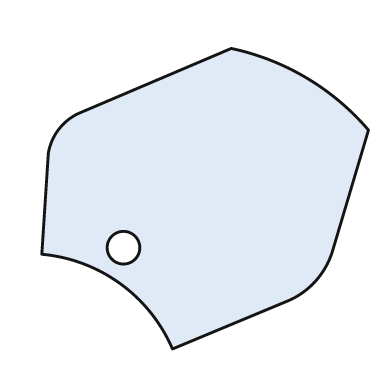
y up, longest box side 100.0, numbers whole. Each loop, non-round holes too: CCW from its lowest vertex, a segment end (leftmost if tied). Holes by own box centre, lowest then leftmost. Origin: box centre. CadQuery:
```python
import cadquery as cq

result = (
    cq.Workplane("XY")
    .moveTo(-10.0, -46.0)
    .lineTo(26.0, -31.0)
    .threePointArc((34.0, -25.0), (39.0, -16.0))
    .lineTo(50.0, 21.0)
    .threePointArc((31.0, 37.0), (8.0, 46.0))
    .lineTo(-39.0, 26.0)
    .threePointArc((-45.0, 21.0), (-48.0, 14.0))
    .lineTo(-50.0, -17.0)
    .threePointArc((-26.0, -26.0), (-10.0, -46.0))
    .close()
    .moveTo(-25.0, -15.0)
    .circle(5.0)
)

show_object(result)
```